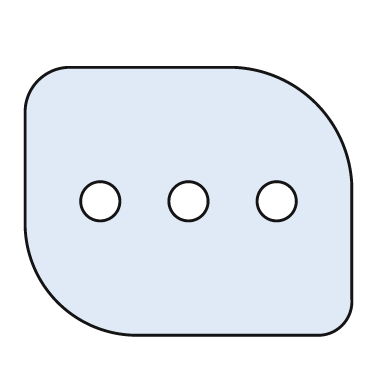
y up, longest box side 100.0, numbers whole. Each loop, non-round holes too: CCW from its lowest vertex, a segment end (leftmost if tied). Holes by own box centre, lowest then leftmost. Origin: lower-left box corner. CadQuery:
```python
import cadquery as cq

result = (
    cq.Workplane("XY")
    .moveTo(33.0, 0.0)
    .lineTo(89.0, 0.0)
    .threePointArc((97.0, 3.0), (100.0, 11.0))
    .lineTo(100.0, 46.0)
    .threePointArc((89.0, 71.0), (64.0, 82.0))
    .lineTo(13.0, 82.0)
    .threePointArc((4.0, 78.0), (0.0, 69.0))
    .lineTo(0.0, 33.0)
    .threePointArc((10.0, 10.0), (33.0, 0.0))
    .close()
    .moveTo(23.0, 41.0)
    .circle(6.0)
    .moveTo(50.0, 41.0)
    .circle(6.0)
    .moveTo(77.0, 41.0)
    .circle(6.0)
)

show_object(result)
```